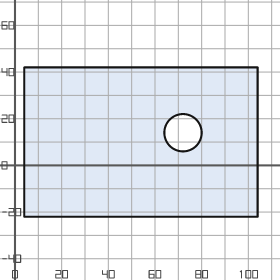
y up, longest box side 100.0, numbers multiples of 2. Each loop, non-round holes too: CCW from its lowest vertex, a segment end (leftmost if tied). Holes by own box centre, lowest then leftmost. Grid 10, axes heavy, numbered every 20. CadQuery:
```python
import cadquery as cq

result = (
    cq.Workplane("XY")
    .moveTo(4.0, -22.0)
    .lineTo(104.0, -22.0)
    .lineTo(104.0, 42.0)
    .lineTo(4.0, 42.0)
    .close()
    .moveTo(72.0, 14.0)
    .circle(8.0)
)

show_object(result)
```